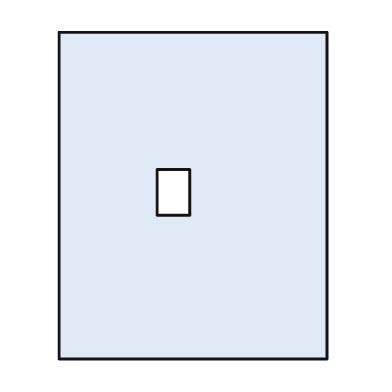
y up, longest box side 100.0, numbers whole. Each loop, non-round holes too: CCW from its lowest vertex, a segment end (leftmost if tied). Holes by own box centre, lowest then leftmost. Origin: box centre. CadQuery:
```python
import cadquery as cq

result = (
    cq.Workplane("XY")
    .moveTo(-41.0, -50.0)
    .lineTo(41.0, -50.0)
    .lineTo(41.0, 50.0)
    .lineTo(-41.0, 50.0)
    .close()
    .moveTo(-11.0, -6.0)
    .lineTo(-1.0, -6.0)
    .lineTo(-1.0, 8.0)
    .lineTo(-11.0, 8.0)
    .close()
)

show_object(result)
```